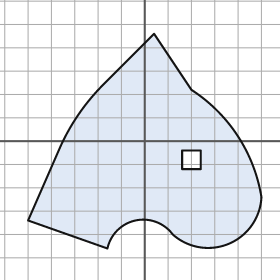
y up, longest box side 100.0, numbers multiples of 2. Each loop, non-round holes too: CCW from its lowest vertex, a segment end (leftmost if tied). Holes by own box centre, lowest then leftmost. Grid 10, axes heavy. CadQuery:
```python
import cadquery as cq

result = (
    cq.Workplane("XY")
    .moveTo(-16.0, -46.0)
    .threePointArc((-4.0, -34.0), (12.0, -40.0))
    .threePointArc((36.0, -44.0), (50.0, -24.0))
    .threePointArc((40.0, 2.0), (20.0, 22.0))
    .lineTo(4.0, 46.0)
    .lineTo(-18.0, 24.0)
    .threePointArc((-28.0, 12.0), (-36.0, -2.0))
    .lineTo(-50.0, -34.0)
    .close()
    .moveTo(16.0, -12.0)
    .lineTo(24.0, -12.0)
    .lineTo(24.0, -4.0)
    .lineTo(16.0, -4.0)
    .close()
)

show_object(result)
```